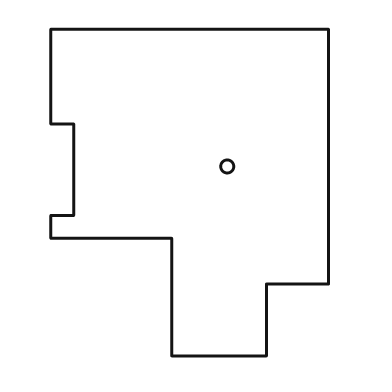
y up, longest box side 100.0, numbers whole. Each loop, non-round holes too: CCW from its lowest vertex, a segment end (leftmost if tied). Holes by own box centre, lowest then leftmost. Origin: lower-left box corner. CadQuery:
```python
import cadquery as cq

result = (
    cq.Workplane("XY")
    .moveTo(37.0, 0.0)
    .lineTo(66.0, 0.0)
    .lineTo(66.0, 22.0)
    .lineTo(85.0, 22.0)
    .lineTo(85.0, 100.0)
    .lineTo(0.0, 100.0)
    .lineTo(0.0, 71.0)
    .lineTo(7.0, 71.0)
    .lineTo(7.0, 43.0)
    .lineTo(0.0, 43.0)
    .lineTo(0.0, 36.0)
    .lineTo(37.0, 36.0)
    .close()
    .moveTo(54.0, 58.0)
    .circle(2.0)
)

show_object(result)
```